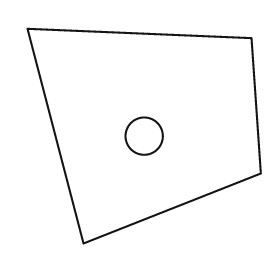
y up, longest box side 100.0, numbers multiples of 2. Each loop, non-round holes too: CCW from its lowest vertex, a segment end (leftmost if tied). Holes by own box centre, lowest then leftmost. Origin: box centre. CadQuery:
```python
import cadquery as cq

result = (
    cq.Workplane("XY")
    .moveTo(-26.0, -46.0)
    .lineTo(50.0, -16.0)
    .lineTo(46.0, 42.0)
    .lineTo(-50.0, 46.0)
    .close()
    .moveTo(0.0, 0.0)
    .circle(8.0)
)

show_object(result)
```